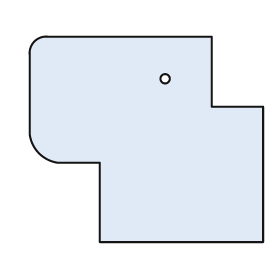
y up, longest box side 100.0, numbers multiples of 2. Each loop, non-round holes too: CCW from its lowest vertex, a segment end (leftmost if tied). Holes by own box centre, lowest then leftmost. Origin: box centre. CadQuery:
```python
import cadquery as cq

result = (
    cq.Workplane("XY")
    .moveTo(-20.0, -44.0)
    .lineTo(50.0, -44.0)
    .lineTo(50.0, 14.0)
    .lineTo(28.0, 14.0)
    .lineTo(28.0, 44.0)
    .lineTo(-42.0, 44.0)
    .threePointArc((-48.0, 42.0), (-50.0, 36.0))
    .lineTo(-50.0, 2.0)
    .threePointArc((-46.0, -6.0), (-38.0, -10.0))
    .lineTo(-20.0, -10.0)
    .close()
    .moveTo(8.0, 26.0)
    .circle(2.0)
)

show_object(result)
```